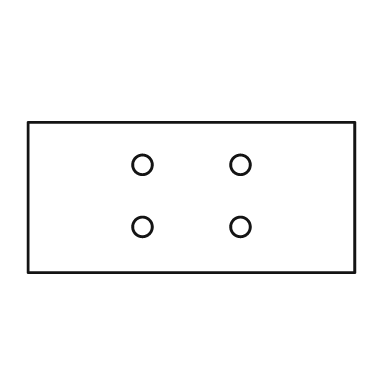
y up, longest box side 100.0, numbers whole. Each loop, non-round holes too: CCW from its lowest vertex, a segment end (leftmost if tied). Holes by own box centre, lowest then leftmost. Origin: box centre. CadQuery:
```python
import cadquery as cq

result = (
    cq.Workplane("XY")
    .moveTo(-50.0, -23.0)
    .lineTo(50.0, -23.0)
    .lineTo(50.0, 23.0)
    .lineTo(-50.0, 23.0)
    .close()
    .moveTo(-15.0, -9.0)
    .circle(3.0)
    .moveTo(15.0, -9.0)
    .circle(3.0)
    .moveTo(-15.0, 10.0)
    .circle(3.0)
    .moveTo(15.0, 10.0)
    .circle(3.0)
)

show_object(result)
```